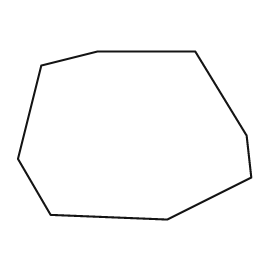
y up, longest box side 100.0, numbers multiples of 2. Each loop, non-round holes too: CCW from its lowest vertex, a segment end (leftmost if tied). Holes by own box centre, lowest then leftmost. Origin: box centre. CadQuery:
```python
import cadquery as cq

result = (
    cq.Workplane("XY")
    .moveTo(14.0, -36.0)
    .lineTo(50.0, -18.0)
    .lineTo(48.0, 0.0)
    .lineTo(26.0, 36.0)
    .lineTo(-16.0, 36.0)
    .lineTo(-40.0, 30.0)
    .lineTo(-50.0, -10.0)
    .lineTo(-36.0, -34.0)
    .close()
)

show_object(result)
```